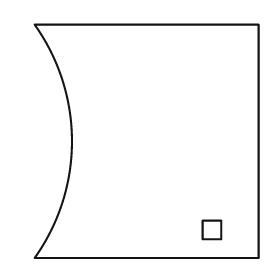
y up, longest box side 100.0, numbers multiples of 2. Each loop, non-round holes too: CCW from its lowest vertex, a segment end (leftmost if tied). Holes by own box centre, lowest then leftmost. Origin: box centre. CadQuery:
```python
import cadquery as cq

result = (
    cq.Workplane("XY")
    .moveTo(-48.0, -50.0)
    .lineTo(48.0, -50.0)
    .lineTo(48.0, 50.0)
    .lineTo(-48.0, 50.0)
    .threePointArc((-32.0, 0.0), (-48.0, -50.0))
    .close()
    .moveTo(24.0, -42.0)
    .lineTo(32.0, -42.0)
    .lineTo(32.0, -34.0)
    .lineTo(24.0, -34.0)
    .close()
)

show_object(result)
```